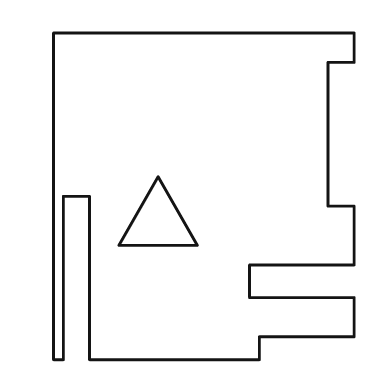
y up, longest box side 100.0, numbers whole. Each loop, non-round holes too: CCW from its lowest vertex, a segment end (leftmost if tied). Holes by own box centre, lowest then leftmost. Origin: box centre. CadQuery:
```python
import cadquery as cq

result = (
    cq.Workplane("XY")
    .moveTo(-46.0, -50.0)
    .lineTo(-43.0, -50.0)
    .lineTo(-43.0, 0.0)
    .lineTo(-35.0, 0.0)
    .lineTo(-35.0, -50.0)
    .lineTo(17.0, -50.0)
    .lineTo(17.0, -43.0)
    .lineTo(46.0, -43.0)
    .lineTo(46.0, -31.0)
    .lineTo(14.0, -31.0)
    .lineTo(14.0, -21.0)
    .lineTo(46.0, -21.0)
    .lineTo(46.0, -3.0)
    .lineTo(38.0, -3.0)
    .lineTo(38.0, 41.0)
    .lineTo(46.0, 41.0)
    .lineTo(46.0, 50.0)
    .lineTo(-46.0, 50.0)
    .close()
    .moveTo(-26.0, -15.0)
    .lineTo(-2.0, -15.0)
    .lineTo(-14.0, 6.0)
    .close()
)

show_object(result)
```